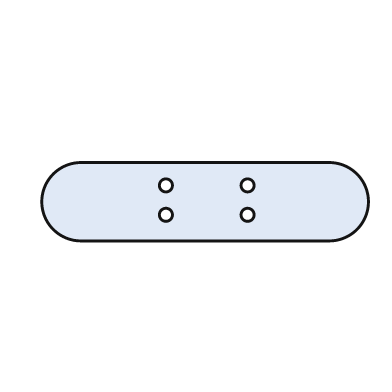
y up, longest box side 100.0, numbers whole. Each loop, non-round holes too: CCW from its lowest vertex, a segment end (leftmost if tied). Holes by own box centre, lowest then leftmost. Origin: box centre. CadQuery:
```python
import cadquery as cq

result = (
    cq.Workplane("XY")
    .moveTo(-38.0, -12.0)
    .lineTo(38.0, -12.0)
    .threePointArc((50.0, 0.0), (38.0, 12.0))
    .lineTo(-38.0, 12.0)
    .threePointArc((-50.0, 0.0), (-38.0, -12.0))
    .close()
    .moveTo(-12.0, -4.0)
    .circle(2.0)
    .moveTo(13.0, -4.0)
    .circle(2.0)
    .moveTo(-12.0, 5.0)
    .circle(2.0)
    .moveTo(13.0, 5.0)
    .circle(2.0)
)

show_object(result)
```